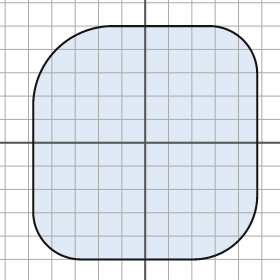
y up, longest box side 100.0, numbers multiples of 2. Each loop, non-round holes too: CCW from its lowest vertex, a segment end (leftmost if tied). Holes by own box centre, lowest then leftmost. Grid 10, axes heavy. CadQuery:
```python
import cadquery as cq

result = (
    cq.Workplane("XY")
    .moveTo(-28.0, -50.0)
    .lineTo(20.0, -50.0)
    .threePointArc((40.0, -42.0), (48.0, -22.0))
    .lineTo(48.0, 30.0)
    .threePointArc((42.0, 44.0), (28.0, 50.0))
    .lineTo(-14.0, 50.0)
    .threePointArc((-38.0, 40.0), (-48.0, 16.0))
    .lineTo(-48.0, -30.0)
    .threePointArc((-42.0, -44.0), (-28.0, -50.0))
    .close()
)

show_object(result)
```